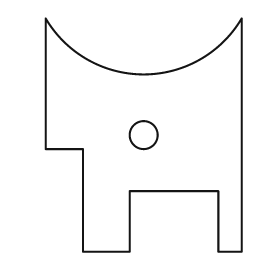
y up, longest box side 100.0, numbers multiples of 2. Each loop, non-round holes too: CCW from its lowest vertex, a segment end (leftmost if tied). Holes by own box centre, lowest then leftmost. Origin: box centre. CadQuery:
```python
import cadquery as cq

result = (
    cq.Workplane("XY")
    .moveTo(-26.0, -50.0)
    .lineTo(-6.0, -50.0)
    .lineTo(-6.0, -24.0)
    .lineTo(32.0, -24.0)
    .lineTo(32.0, -50.0)
    .lineTo(42.0, -50.0)
    .lineTo(42.0, 50.0)
    .threePointArc((0.0, 26.0), (-42.0, 50.0))
    .lineTo(-42.0, -6.0)
    .lineTo(-26.0, -6.0)
    .close()
    .moveTo(0.0, 0.0)
    .circle(6.0)
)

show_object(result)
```